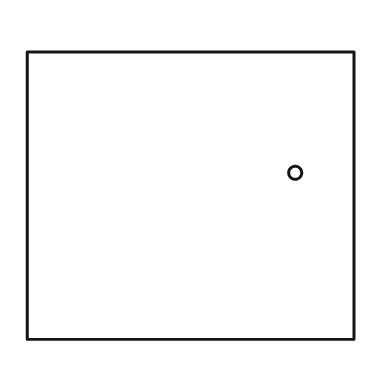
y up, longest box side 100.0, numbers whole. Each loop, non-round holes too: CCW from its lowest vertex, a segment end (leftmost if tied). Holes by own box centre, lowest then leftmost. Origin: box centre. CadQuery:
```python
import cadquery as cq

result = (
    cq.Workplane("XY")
    .moveTo(-50.0, -44.0)
    .lineTo(50.0, -44.0)
    .lineTo(50.0, 44.0)
    .lineTo(-50.0, 44.0)
    .close()
    .moveTo(32.0, 7.0)
    .circle(2.0)
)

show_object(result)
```